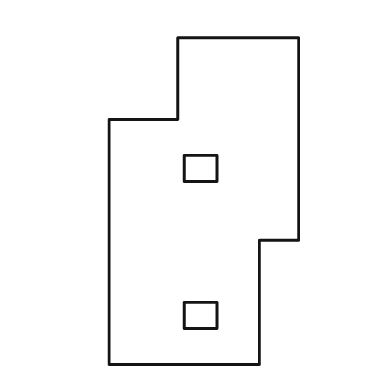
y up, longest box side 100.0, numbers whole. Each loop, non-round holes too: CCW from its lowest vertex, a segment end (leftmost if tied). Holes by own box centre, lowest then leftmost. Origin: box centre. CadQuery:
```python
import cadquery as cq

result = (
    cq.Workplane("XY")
    .moveTo(-29.0, -50.0)
    .lineTo(17.0, -50.0)
    .lineTo(17.0, -12.0)
    .lineTo(29.0, -12.0)
    .lineTo(29.0, 50.0)
    .lineTo(-8.0, 50.0)
    .lineTo(-8.0, 25.0)
    .lineTo(-29.0, 25.0)
    .close()
    .moveTo(-6.0, -39.0)
    .lineTo(4.0, -39.0)
    .lineTo(4.0, -31.0)
    .lineTo(-6.0, -31.0)
    .close()
    .moveTo(-6.0, 6.0)
    .lineTo(4.0, 6.0)
    .lineTo(4.0, 14.0)
    .lineTo(-6.0, 14.0)
    .close()
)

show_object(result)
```